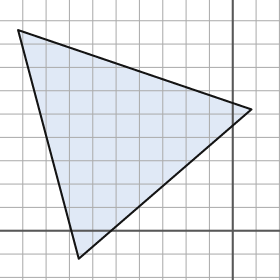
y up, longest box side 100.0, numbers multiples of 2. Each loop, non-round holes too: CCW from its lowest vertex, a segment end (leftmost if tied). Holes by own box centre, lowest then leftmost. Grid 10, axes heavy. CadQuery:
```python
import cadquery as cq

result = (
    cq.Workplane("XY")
    .moveTo(-66.0, -12.0)
    .lineTo(8.0, 52.0)
    .lineTo(-92.0, 86.0)
    .close()
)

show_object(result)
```